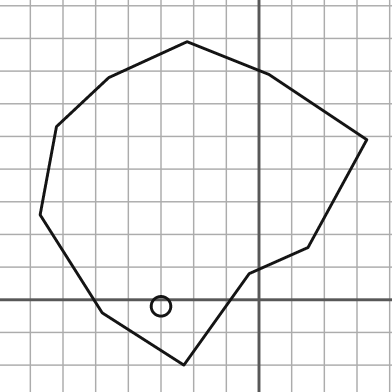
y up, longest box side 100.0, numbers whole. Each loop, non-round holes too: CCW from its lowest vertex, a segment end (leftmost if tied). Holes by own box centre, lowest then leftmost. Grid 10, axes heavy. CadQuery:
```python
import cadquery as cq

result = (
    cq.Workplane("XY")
    .moveTo(-23.0, -20.0)
    .lineTo(-3.0, 8.0)
    .lineTo(15.0, 16.0)
    .lineTo(33.0, 49.0)
    .lineTo(3.0, 69.0)
    .lineTo(-22.0, 79.0)
    .lineTo(-46.0, 68.0)
    .lineTo(-62.0, 53.0)
    .lineTo(-67.0, 26.0)
    .lineTo(-48.0, -4.0)
    .close()
    .moveTo(-30.0, -2.0)
    .circle(3.0)
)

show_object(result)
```